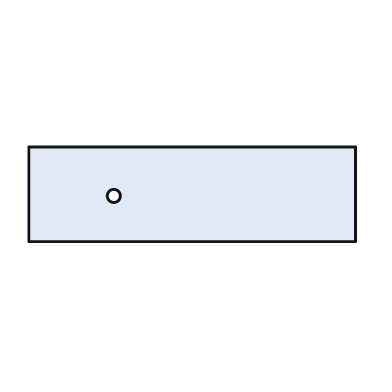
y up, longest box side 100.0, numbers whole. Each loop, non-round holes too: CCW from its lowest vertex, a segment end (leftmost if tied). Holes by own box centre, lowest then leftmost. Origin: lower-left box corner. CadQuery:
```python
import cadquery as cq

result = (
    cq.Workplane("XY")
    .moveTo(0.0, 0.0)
    .lineTo(100.0, 0.0)
    .lineTo(100.0, 29.0)
    .lineTo(0.0, 29.0)
    .close()
    .moveTo(26.0, 14.0)
    .circle(2.0)
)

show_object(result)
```